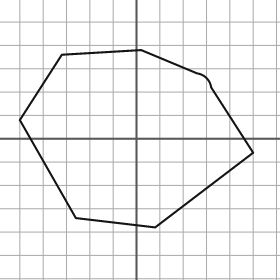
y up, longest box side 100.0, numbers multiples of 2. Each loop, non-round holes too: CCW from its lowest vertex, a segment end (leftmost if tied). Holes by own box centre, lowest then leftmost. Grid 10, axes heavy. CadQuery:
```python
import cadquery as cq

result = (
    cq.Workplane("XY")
    .moveTo(8.0, -38.0)
    .lineTo(50.0, -6.0)
    .lineTo(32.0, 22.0)
    .threePointArc((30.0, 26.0), (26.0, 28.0))
    .lineTo(2.0, 38.0)
    .lineTo(-32.0, 36.0)
    .lineTo(-50.0, 8.0)
    .lineTo(-26.0, -34.0)
    .close()
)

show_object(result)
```